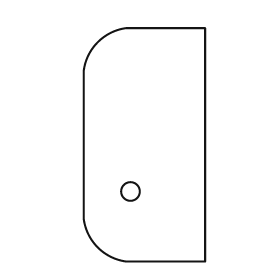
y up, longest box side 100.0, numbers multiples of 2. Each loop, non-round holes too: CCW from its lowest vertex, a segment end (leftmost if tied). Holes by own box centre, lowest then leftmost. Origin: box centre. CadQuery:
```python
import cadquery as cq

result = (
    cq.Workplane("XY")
    .moveTo(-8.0, -50.0)
    .lineTo(26.0, -50.0)
    .lineTo(26.0, 50.0)
    .lineTo(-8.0, 50.0)
    .threePointArc((-20.0, 44.0), (-26.0, 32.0))
    .lineTo(-26.0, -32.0)
    .threePointArc((-20.0, -44.0), (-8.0, -50.0))
    .close()
    .moveTo(-6.0, -20.0)
    .circle(4.0)
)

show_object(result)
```